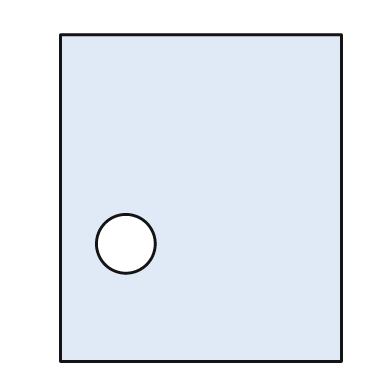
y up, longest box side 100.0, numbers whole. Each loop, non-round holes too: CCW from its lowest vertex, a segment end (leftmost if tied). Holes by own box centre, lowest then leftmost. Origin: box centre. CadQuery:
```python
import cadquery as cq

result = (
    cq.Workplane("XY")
    .moveTo(-43.0, -50.0)
    .lineTo(43.0, -50.0)
    .lineTo(43.0, 50.0)
    .lineTo(-43.0, 50.0)
    .close()
    .moveTo(-23.0, -14.0)
    .circle(9.0)
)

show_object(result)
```